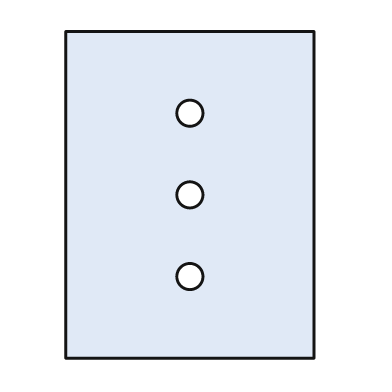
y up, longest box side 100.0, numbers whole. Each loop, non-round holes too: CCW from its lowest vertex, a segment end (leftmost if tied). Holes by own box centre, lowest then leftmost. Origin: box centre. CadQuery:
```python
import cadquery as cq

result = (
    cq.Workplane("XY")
    .moveTo(-38.0, -50.0)
    .lineTo(38.0, -50.0)
    .lineTo(38.0, 50.0)
    .lineTo(-38.0, 50.0)
    .close()
    .moveTo(0.0, -25.0)
    .circle(4.0)
    .moveTo(0.0, 0.0)
    .circle(4.0)
    .moveTo(0.0, 25.0)
    .circle(4.0)
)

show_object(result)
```